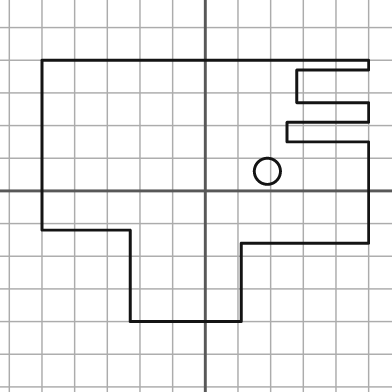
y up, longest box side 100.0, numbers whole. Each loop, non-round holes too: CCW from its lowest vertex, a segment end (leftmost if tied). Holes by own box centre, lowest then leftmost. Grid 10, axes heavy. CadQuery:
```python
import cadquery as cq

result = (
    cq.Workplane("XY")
    .moveTo(-23.0, -40.0)
    .lineTo(11.0, -40.0)
    .lineTo(11.0, -16.0)
    .lineTo(50.0, -16.0)
    .lineTo(50.0, 15.0)
    .lineTo(25.0, 15.0)
    .lineTo(25.0, 21.0)
    .lineTo(50.0, 21.0)
    .lineTo(50.0, 27.0)
    .lineTo(28.0, 27.0)
    .lineTo(28.0, 37.0)
    .lineTo(50.0, 37.0)
    .lineTo(50.0, 40.0)
    .lineTo(-50.0, 40.0)
    .lineTo(-50.0, -12.0)
    .lineTo(-23.0, -12.0)
    .close()
    .moveTo(19.0, 6.0)
    .circle(4.0)
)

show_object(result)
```